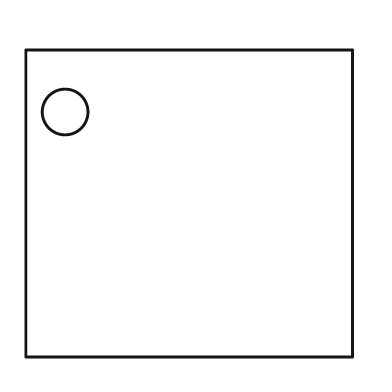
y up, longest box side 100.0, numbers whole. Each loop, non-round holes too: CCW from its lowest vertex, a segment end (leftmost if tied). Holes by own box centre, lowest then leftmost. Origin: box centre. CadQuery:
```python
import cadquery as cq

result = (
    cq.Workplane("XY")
    .moveTo(-50.0, -47.0)
    .lineTo(50.0, -47.0)
    .lineTo(50.0, 47.0)
    .lineTo(-50.0, 47.0)
    .close()
    .moveTo(-38.0, 28.0)
    .circle(7.0)
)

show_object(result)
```